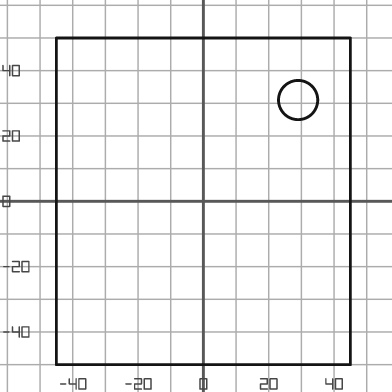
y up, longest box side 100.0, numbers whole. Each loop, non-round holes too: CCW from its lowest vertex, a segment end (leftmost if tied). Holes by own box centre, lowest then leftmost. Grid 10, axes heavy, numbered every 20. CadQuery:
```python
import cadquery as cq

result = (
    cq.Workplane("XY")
    .moveTo(-45.0, -50.0)
    .lineTo(45.0, -50.0)
    .lineTo(45.0, 50.0)
    .lineTo(-45.0, 50.0)
    .close()
    .moveTo(29.0, 31.0)
    .circle(6.0)
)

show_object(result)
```